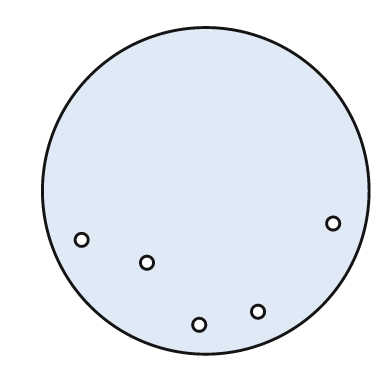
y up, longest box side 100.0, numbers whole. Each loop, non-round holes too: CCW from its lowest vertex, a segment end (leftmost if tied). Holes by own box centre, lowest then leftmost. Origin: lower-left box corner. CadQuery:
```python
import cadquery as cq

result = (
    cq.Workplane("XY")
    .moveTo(50.0, 50.0)
    .circle(50.0)
    .moveTo(48.0, 9.0)
    .circle(2.0)
    .moveTo(66.0, 13.0)
    .circle(2.0)
    .moveTo(32.0, 28.0)
    .circle(2.0)
    .moveTo(12.0, 35.0)
    .circle(2.0)
    .moveTo(89.0, 40.0)
    .circle(2.0)
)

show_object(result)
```